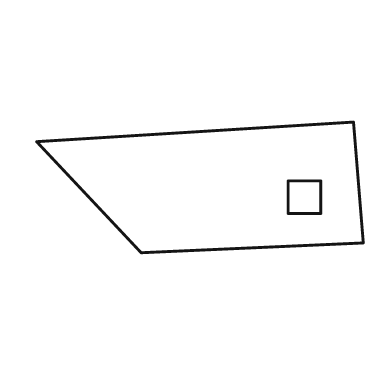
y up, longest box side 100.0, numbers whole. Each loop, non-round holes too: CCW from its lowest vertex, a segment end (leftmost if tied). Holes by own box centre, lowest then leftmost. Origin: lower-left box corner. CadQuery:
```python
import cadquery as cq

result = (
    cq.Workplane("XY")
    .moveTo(32.0, 0.0)
    .lineTo(100.0, 3.0)
    .lineTo(97.0, 40.0)
    .lineTo(0.0, 34.0)
    .close()
    .moveTo(77.0, 12.0)
    .lineTo(87.0, 12.0)
    .lineTo(87.0, 22.0)
    .lineTo(77.0, 22.0)
    .close()
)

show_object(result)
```